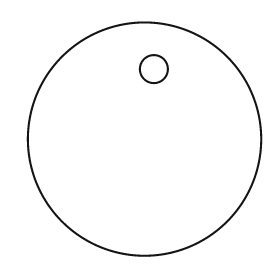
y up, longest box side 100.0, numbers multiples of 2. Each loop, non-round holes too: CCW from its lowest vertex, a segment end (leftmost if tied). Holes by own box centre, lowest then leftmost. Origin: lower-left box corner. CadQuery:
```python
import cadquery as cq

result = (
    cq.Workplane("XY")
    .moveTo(50.0, 50.0)
    .circle(50.0)
    .moveTo(54.0, 80.0)
    .circle(6.0)
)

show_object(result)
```